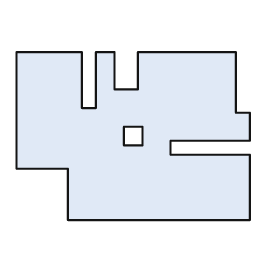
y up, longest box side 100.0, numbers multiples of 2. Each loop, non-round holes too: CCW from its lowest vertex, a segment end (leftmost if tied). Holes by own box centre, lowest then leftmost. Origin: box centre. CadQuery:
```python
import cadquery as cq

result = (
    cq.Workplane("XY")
    .moveTo(-28.0, -36.0)
    .lineTo(50.0, -36.0)
    .lineTo(50.0, -8.0)
    .lineTo(16.0, -8.0)
    .lineTo(16.0, -2.0)
    .lineTo(50.0, -2.0)
    .lineTo(50.0, 10.0)
    .lineTo(44.0, 10.0)
    .lineTo(44.0, 36.0)
    .lineTo(2.0, 36.0)
    .lineTo(2.0, 20.0)
    .lineTo(-8.0, 20.0)
    .lineTo(-8.0, 36.0)
    .lineTo(-16.0, 36.0)
    .lineTo(-16.0, 12.0)
    .lineTo(-22.0, 12.0)
    .lineTo(-22.0, 36.0)
    .lineTo(-50.0, 36.0)
    .lineTo(-50.0, -14.0)
    .lineTo(-28.0, -14.0)
    .close()
    .moveTo(-4.0, -4.0)
    .lineTo(4.0, -4.0)
    .lineTo(4.0, 4.0)
    .lineTo(-4.0, 4.0)
    .close()
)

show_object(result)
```